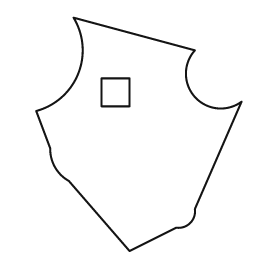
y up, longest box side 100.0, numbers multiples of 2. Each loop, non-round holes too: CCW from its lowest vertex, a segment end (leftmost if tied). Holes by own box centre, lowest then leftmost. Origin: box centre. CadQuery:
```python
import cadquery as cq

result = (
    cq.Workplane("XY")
    .moveTo(-4.0, -50.0)
    .lineTo(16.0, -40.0)
    .threePointArc((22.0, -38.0), (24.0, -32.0))
    .lineTo(44.0, 14.0)
    .threePointArc((24.0, 16.0), (24.0, 36.0))
    .lineTo(-28.0, 50.0)
    .threePointArc((-26.0, 26.0), (-44.0, 10.0))
    .lineTo(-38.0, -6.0)
    .threePointArc((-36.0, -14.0), (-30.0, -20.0))
    .close()
    .moveTo(-16.0, 12.0)
    .lineTo(-4.0, 12.0)
    .lineTo(-4.0, 24.0)
    .lineTo(-16.0, 24.0)
    .close()
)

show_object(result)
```